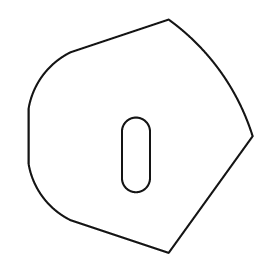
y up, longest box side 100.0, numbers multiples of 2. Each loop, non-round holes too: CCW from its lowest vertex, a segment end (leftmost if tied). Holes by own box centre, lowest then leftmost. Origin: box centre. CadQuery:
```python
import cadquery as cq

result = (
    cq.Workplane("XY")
    .moveTo(12.0, -50.0)
    .lineTo(48.0, 0.0)
    .threePointArc((34.0, 28.0), (12.0, 50.0))
    .lineTo(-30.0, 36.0)
    .threePointArc((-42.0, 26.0), (-48.0, 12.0))
    .lineTo(-48.0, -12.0)
    .threePointArc((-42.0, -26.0), (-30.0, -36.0))
    .close()
    .moveTo(-8.0, -18.0)
    .threePointArc((-2.0, -24.0), (4.0, -18.0))
    .lineTo(4.0, 2.0)
    .threePointArc((-2.0, 8.0), (-8.0, 2.0))
    .close()
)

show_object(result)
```